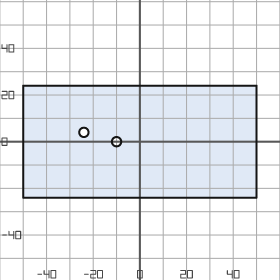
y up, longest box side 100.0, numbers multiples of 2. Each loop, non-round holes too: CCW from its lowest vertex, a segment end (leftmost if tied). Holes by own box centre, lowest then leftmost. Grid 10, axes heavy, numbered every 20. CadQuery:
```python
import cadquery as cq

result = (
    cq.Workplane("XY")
    .moveTo(-50.0, -24.0)
    .lineTo(50.0, -24.0)
    .lineTo(50.0, 24.0)
    .lineTo(-50.0, 24.0)
    .close()
    .moveTo(-10.0, 0.0)
    .circle(2.0)
    .moveTo(-24.0, 4.0)
    .circle(2.0)
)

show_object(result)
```